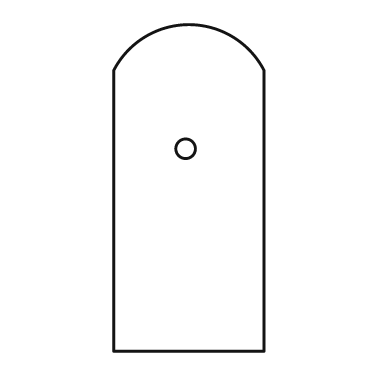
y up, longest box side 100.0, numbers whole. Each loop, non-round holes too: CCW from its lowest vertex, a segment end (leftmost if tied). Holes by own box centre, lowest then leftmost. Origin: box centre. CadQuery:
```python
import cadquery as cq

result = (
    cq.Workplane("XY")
    .moveTo(-23.0, -50.0)
    .lineTo(23.0, -50.0)
    .lineTo(23.0, 36.0)
    .threePointArc((0.0, 50.0), (-23.0, 36.0))
    .close()
    .moveTo(-1.0, 12.0)
    .circle(3.0)
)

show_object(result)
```